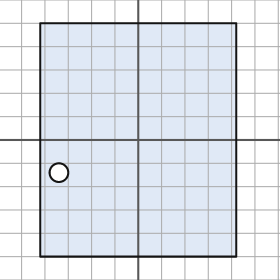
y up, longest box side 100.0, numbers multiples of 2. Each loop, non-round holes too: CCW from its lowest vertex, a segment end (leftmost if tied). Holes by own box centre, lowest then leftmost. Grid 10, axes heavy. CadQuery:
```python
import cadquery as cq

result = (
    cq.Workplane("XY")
    .moveTo(-42.0, -50.0)
    .lineTo(42.0, -50.0)
    .lineTo(42.0, 50.0)
    .lineTo(-42.0, 50.0)
    .close()
    .moveTo(-34.0, -14.0)
    .circle(4.0)
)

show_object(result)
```